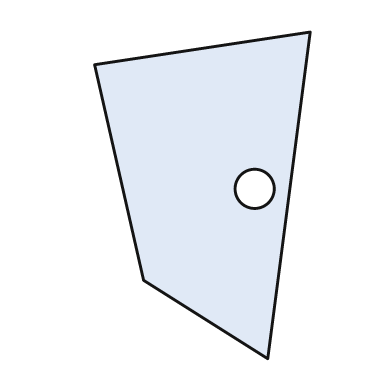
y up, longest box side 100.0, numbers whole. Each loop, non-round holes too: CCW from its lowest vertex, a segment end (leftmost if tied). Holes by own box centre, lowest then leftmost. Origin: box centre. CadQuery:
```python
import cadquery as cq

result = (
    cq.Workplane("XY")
    .moveTo(20.0, -50.0)
    .lineTo(33.0, 50.0)
    .lineTo(-33.0, 40.0)
    .lineTo(-18.0, -26.0)
    .close()
    .moveTo(16.0, 2.0)
    .circle(6.0)
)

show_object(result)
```